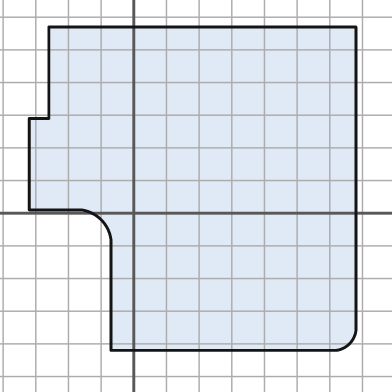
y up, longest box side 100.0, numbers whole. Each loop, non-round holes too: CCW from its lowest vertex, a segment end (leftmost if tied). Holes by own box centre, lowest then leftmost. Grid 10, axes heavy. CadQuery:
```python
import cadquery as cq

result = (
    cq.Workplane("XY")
    .moveTo(-7.0, -42.0)
    .lineTo(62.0, -42.0)
    .threePointArc((66.0, -40.0), (68.0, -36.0))
    .lineTo(68.0, 57.0)
    .lineTo(-26.0, 57.0)
    .lineTo(-26.0, 29.0)
    .lineTo(-32.0, 29.0)
    .lineTo(-32.0, 1.0)
    .lineTo(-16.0, 1.0)
    .threePointArc((-10.0, -2.0), (-7.0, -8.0))
    .close()
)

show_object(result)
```